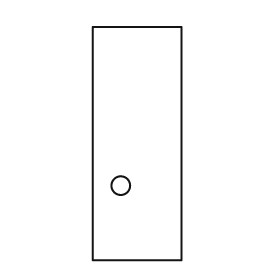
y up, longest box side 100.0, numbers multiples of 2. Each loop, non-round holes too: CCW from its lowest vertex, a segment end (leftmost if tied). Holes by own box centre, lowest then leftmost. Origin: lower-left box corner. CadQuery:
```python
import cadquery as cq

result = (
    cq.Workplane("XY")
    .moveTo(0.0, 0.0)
    .lineTo(38.0, 0.0)
    .lineTo(38.0, 100.0)
    .lineTo(0.0, 100.0)
    .close()
    .moveTo(12.0, 32.0)
    .circle(4.0)
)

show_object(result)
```